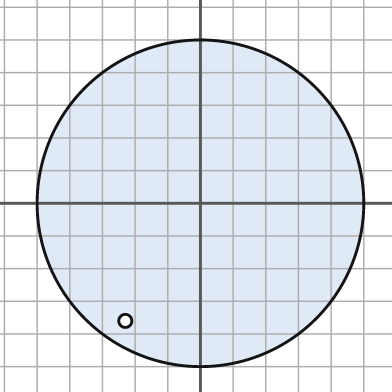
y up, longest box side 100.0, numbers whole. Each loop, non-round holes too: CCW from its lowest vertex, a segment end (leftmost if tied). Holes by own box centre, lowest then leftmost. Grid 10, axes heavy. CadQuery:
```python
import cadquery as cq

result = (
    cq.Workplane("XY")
    .moveTo(0.0, 0.0)
    .circle(50.0)
    .moveTo(-23.0, -36.0)
    .circle(2.0)
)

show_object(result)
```